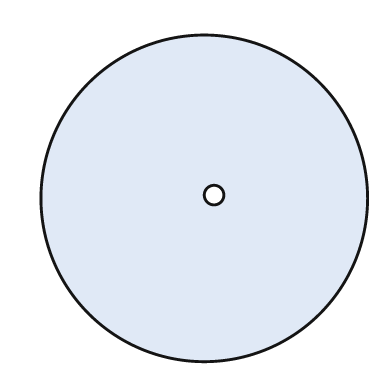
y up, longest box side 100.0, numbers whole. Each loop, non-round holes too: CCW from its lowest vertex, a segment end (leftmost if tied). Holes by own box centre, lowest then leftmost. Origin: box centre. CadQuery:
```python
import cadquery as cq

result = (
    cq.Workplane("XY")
    .moveTo(0.0, 0.0)
    .circle(50.0)
    .moveTo(3.0, 1.0)
    .circle(3.0)
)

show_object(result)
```